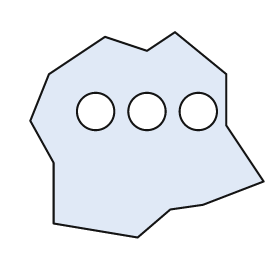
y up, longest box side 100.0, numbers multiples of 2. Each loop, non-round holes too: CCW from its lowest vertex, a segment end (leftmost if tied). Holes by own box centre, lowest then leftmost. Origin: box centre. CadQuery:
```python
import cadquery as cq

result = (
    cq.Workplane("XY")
    .moveTo(-4.0, -44.0)
    .lineTo(10.0, -32.0)
    .lineTo(24.0, -30.0)
    .lineTo(50.0, -20.0)
    .lineTo(34.0, 4.0)
    .lineTo(34.0, 26.0)
    .lineTo(12.0, 44.0)
    .lineTo(0.0, 36.0)
    .lineTo(-18.0, 42.0)
    .lineTo(-42.0, 26.0)
    .lineTo(-50.0, 6.0)
    .lineTo(-40.0, -12.0)
    .lineTo(-40.0, -38.0)
    .close()
    .moveTo(-22.0, 10.0)
    .circle(8.0)
    .moveTo(0.0, 10.0)
    .circle(8.0)
    .moveTo(22.0, 10.0)
    .circle(8.0)
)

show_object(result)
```